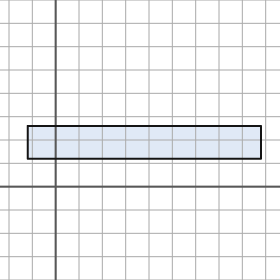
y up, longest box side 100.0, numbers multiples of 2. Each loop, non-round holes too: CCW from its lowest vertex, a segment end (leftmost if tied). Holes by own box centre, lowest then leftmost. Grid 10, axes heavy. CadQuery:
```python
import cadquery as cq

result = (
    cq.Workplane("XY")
    .moveTo(-12.0, 12.0)
    .lineTo(88.0, 12.0)
    .lineTo(88.0, 26.0)
    .lineTo(-12.0, 26.0)
    .close()
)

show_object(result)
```